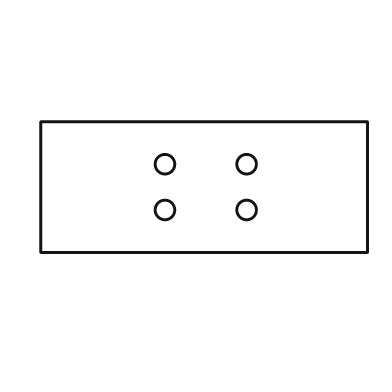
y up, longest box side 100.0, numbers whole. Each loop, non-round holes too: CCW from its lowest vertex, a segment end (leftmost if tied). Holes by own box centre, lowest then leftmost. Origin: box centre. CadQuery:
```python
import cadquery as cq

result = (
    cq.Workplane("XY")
    .moveTo(-50.0, -20.0)
    .lineTo(50.0, -20.0)
    .lineTo(50.0, 20.0)
    .lineTo(-50.0, 20.0)
    .close()
    .moveTo(-12.0, -7.0)
    .circle(3.0)
    .moveTo(13.0, -7.0)
    .circle(3.0)
    .moveTo(-12.0, 7.0)
    .circle(3.0)
    .moveTo(13.0, 7.0)
    .circle(3.0)
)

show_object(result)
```